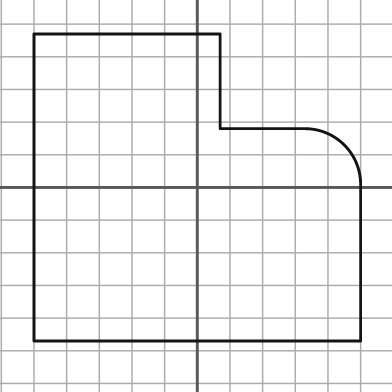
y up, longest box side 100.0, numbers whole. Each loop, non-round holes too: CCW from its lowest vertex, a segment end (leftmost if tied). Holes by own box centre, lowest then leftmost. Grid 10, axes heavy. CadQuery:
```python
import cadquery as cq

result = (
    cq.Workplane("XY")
    .moveTo(-50.0, -47.0)
    .lineTo(50.0, -47.0)
    .lineTo(50.0, 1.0)
    .threePointArc((45.0, 13.0), (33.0, 18.0))
    .lineTo(7.0, 18.0)
    .lineTo(7.0, 47.0)
    .lineTo(-50.0, 47.0)
    .close()
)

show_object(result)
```